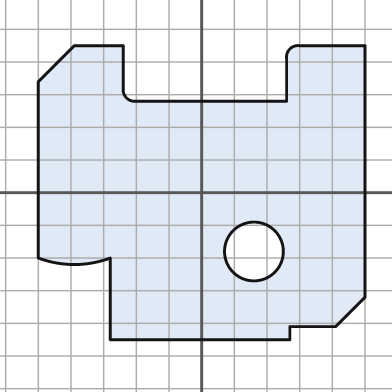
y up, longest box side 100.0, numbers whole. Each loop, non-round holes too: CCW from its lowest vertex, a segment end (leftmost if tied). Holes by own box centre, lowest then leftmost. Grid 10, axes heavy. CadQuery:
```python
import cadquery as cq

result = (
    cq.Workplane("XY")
    .moveTo(-28.0, -45.0)
    .lineTo(27.0, -45.0)
    .lineTo(27.0, -41.0)
    .lineTo(41.0, -41.0)
    .lineTo(50.0, -32.0)
    .lineTo(50.0, 45.0)
    .lineTo(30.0, 45.0)
    .threePointArc((27.0, 44.0), (26.0, 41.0))
    .lineTo(26.0, 28.0)
    .lineTo(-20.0, 28.0)
    .threePointArc((-23.0, 29.0), (-24.0, 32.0))
    .lineTo(-24.0, 45.0)
    .lineTo(-39.0, 45.0)
    .lineTo(-50.0, 34.0)
    .lineTo(-50.0, -20.0)
    .threePointArc((-39.0, -22.0), (-28.0, -20.0))
    .close()
    .moveTo(16.0, -18.0)
    .circle(9.0)
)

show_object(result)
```